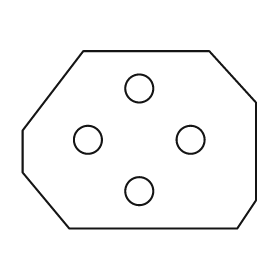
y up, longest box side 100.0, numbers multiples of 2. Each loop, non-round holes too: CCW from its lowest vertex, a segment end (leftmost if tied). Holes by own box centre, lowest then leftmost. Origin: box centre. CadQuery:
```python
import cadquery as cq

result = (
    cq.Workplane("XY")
    .moveTo(-30.0, -38.0)
    .lineTo(42.0, -38.0)
    .lineTo(50.0, -26.0)
    .lineTo(50.0, 16.0)
    .lineTo(30.0, 38.0)
    .lineTo(-24.0, 38.0)
    .lineTo(-50.0, 4.0)
    .lineTo(-50.0, -14.0)
    .close()
    .moveTo(0.0, -22.0)
    .circle(6.0)
    .moveTo(-22.0, 0.0)
    .circle(6.0)
    .moveTo(22.0, 0.0)
    .circle(6.0)
    .moveTo(0.0, 22.0)
    .circle(6.0)
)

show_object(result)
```